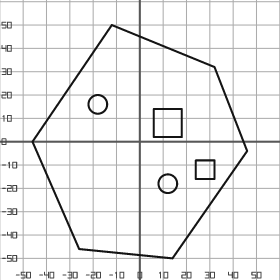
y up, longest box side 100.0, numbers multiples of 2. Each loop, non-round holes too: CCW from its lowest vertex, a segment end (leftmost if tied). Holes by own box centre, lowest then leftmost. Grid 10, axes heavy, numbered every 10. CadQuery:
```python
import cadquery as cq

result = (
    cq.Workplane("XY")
    .moveTo(14.0, -50.0)
    .lineTo(46.0, -4.0)
    .lineTo(32.0, 32.0)
    .lineTo(-12.0, 50.0)
    .lineTo(-46.0, 0.0)
    .lineTo(-26.0, -46.0)
    .close()
    .moveTo(12.0, -18.0)
    .circle(4.0)
    .moveTo(24.0, -16.0)
    .lineTo(32.0, -16.0)
    .lineTo(32.0, -8.0)
    .lineTo(24.0, -8.0)
    .close()
    .moveTo(6.0, 2.0)
    .lineTo(18.0, 2.0)
    .lineTo(18.0, 14.0)
    .lineTo(6.0, 14.0)
    .close()
    .moveTo(-18.0, 16.0)
    .circle(4.0)
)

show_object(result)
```